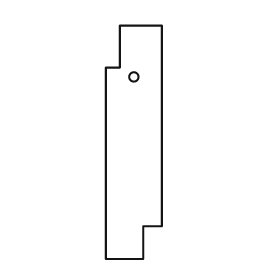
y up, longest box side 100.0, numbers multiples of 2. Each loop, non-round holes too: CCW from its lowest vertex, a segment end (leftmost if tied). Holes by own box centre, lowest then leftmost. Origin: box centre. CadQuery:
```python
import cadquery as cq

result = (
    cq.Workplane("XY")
    .moveTo(-12.0, -50.0)
    .lineTo(4.0, -50.0)
    .lineTo(4.0, -36.0)
    .lineTo(12.0, -36.0)
    .lineTo(12.0, 50.0)
    .lineTo(-6.0, 50.0)
    .lineTo(-6.0, 32.0)
    .lineTo(-12.0, 32.0)
    .close()
    .moveTo(0.0, 28.0)
    .circle(2.0)
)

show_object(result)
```